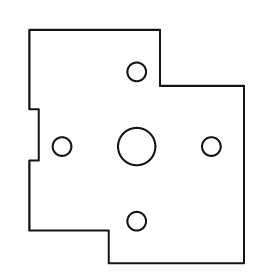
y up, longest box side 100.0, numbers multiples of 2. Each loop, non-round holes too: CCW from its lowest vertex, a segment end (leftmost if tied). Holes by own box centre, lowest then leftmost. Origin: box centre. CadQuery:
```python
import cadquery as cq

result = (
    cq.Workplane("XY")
    .moveTo(-12.0, -50.0)
    .lineTo(46.0, -50.0)
    .lineTo(46.0, 26.0)
    .lineTo(10.0, 26.0)
    .lineTo(10.0, 50.0)
    .lineTo(-46.0, 50.0)
    .lineTo(-46.0, 16.0)
    .lineTo(-42.0, 16.0)
    .lineTo(-42.0, -6.0)
    .lineTo(-46.0, -6.0)
    .lineTo(-46.0, -36.0)
    .lineTo(-12.0, -36.0)
    .close()
    .moveTo(0.0, -32.0)
    .circle(4.0)
    .moveTo(-32.0, 0.0)
    .circle(4.0)
    .moveTo(0.0, 0.0)
    .circle(8.0)
    .moveTo(32.0, 0.0)
    .circle(4.0)
    .moveTo(0.0, 32.0)
    .circle(4.0)
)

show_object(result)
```